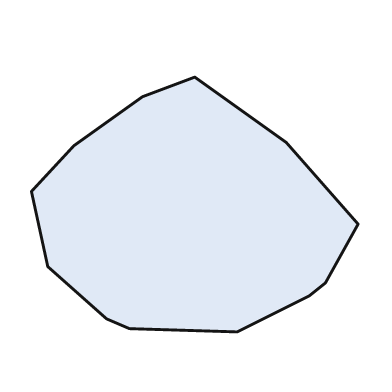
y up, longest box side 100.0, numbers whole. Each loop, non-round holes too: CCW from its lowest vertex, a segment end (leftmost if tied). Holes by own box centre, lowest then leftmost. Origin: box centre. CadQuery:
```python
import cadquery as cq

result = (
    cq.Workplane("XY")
    .moveTo(13.0, -39.0)
    .lineTo(35.0, -28.0)
    .lineTo(40.0, -24.0)
    .lineTo(50.0, -6.0)
    .lineTo(28.0, 19.0)
    .lineTo(0.0, 39.0)
    .lineTo(-16.0, 33.0)
    .lineTo(-37.0, 18.0)
    .lineTo(-50.0, 4.0)
    .lineTo(-45.0, -19.0)
    .lineTo(-27.0, -35.0)
    .lineTo(-20.0, -38.0)
    .close()
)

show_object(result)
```